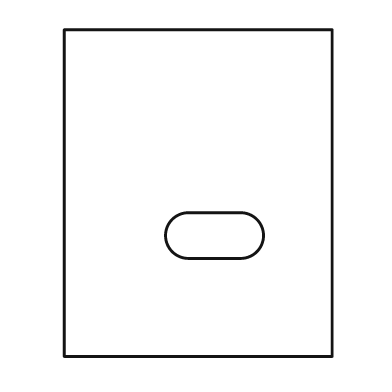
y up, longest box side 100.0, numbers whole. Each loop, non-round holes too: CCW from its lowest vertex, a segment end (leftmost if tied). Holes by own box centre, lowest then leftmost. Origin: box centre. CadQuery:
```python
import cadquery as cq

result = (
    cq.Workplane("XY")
    .moveTo(-41.0, -50.0)
    .lineTo(41.0, -50.0)
    .lineTo(41.0, 50.0)
    .lineTo(-41.0, 50.0)
    .close()
    .moveTo(-3.0, -20.0)
    .lineTo(13.0, -20.0)
    .threePointArc((20.0, -13.0), (13.0, -6.0))
    .lineTo(-3.0, -6.0)
    .threePointArc((-10.0, -13.0), (-3.0, -20.0))
    .close()
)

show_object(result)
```